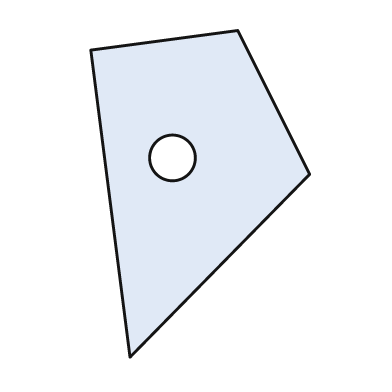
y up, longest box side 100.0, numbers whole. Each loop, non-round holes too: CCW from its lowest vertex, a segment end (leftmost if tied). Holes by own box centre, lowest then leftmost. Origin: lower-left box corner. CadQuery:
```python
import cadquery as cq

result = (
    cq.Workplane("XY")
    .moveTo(12.0, 0.0)
    .lineTo(67.0, 56.0)
    .lineTo(45.0, 100.0)
    .lineTo(0.0, 94.0)
    .close()
    .moveTo(25.0, 61.0)
    .circle(7.0)
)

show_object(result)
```